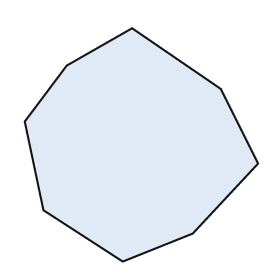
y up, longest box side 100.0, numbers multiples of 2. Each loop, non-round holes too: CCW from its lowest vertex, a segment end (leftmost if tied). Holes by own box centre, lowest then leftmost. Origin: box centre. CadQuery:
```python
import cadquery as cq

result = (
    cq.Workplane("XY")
    .moveTo(-8.0, -50.0)
    .lineTo(22.0, -38.0)
    .lineTo(50.0, -8.0)
    .lineTo(34.0, 24.0)
    .lineTo(-4.0, 50.0)
    .lineTo(-32.0, 34.0)
    .lineTo(-50.0, 10.0)
    .lineTo(-42.0, -28.0)
    .close()
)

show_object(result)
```